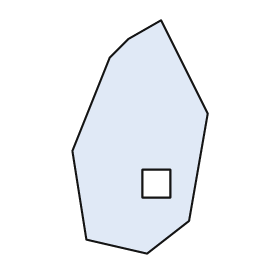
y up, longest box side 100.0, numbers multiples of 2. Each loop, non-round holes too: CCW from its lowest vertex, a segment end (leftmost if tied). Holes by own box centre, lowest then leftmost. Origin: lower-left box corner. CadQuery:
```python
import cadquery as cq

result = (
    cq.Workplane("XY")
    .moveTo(32.0, 0.0)
    .lineTo(50.0, 14.0)
    .lineTo(58.0, 60.0)
    .lineTo(38.0, 100.0)
    .lineTo(24.0, 92.0)
    .lineTo(16.0, 84.0)
    .lineTo(0.0, 44.0)
    .lineTo(6.0, 6.0)
    .close()
    .moveTo(30.0, 24.0)
    .lineTo(42.0, 24.0)
    .lineTo(42.0, 36.0)
    .lineTo(30.0, 36.0)
    .close()
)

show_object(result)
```